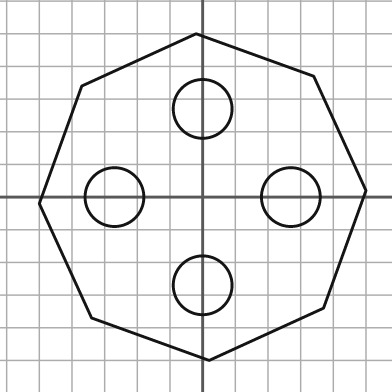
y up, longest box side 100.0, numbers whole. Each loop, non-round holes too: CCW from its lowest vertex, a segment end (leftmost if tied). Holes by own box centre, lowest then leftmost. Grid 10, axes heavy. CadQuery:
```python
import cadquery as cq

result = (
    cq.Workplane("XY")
    .moveTo(2.0, -50.0)
    .lineTo(37.0, -34.0)
    .lineTo(50.0, 2.0)
    .lineTo(34.0, 37.0)
    .lineTo(-2.0, 50.0)
    .lineTo(-37.0, 34.0)
    .lineTo(-50.0, -2.0)
    .lineTo(-34.0, -37.0)
    .close()
    .moveTo(0.0, -27.0)
    .circle(9.0)
    .moveTo(-27.0, 0.0)
    .circle(9.0)
    .moveTo(27.0, 0.0)
    .circle(9.0)
    .moveTo(0.0, 27.0)
    .circle(9.0)
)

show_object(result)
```